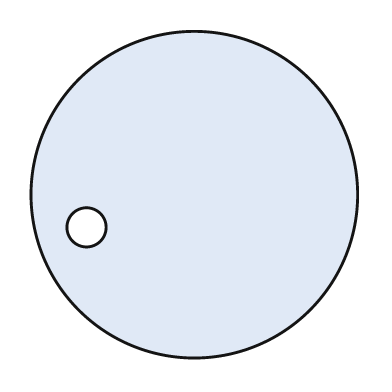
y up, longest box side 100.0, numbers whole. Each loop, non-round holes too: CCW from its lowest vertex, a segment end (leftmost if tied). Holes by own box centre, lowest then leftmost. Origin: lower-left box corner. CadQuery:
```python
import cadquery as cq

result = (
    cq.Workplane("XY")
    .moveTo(50.0, 50.0)
    .circle(50.0)
    .moveTo(17.0, 40.0)
    .circle(6.0)
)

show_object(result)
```